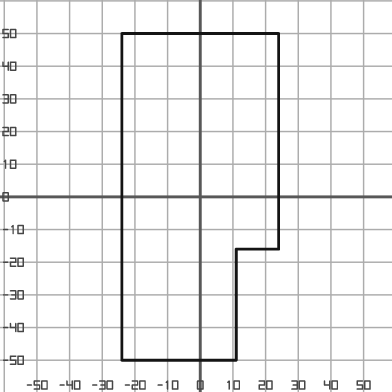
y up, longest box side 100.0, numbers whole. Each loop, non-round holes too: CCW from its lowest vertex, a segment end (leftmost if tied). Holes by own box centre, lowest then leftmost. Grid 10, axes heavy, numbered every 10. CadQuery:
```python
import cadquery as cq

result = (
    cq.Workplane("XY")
    .moveTo(-24.0, -50.0)
    .lineTo(11.0, -50.0)
    .lineTo(11.0, -16.0)
    .lineTo(24.0, -16.0)
    .lineTo(24.0, 50.0)
    .lineTo(-24.0, 50.0)
    .close()
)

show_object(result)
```